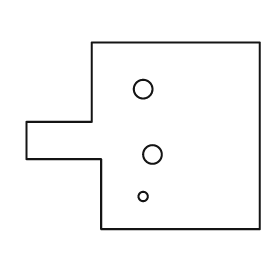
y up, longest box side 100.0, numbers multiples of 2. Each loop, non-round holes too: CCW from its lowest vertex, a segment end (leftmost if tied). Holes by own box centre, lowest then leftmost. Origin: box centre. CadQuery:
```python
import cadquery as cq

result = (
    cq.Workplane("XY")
    .moveTo(-18.0, -40.0)
    .lineTo(50.0, -40.0)
    .lineTo(50.0, 40.0)
    .lineTo(-22.0, 40.0)
    .lineTo(-22.0, 6.0)
    .lineTo(-50.0, 6.0)
    .lineTo(-50.0, -10.0)
    .lineTo(-18.0, -10.0)
    .close()
    .moveTo(0.0, -26.0)
    .circle(2.0)
    .moveTo(4.0, -8.0)
    .circle(4.0)
    .moveTo(0.0, 20.0)
    .circle(4.0)
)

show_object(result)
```